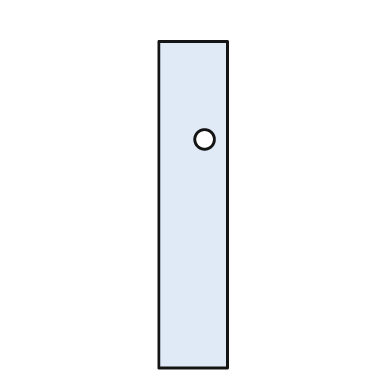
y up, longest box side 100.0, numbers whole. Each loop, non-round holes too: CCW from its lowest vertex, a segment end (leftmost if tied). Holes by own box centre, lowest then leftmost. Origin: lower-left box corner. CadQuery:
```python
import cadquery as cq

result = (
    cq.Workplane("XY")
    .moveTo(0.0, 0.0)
    .lineTo(21.0, 0.0)
    .lineTo(21.0, 100.0)
    .lineTo(0.0, 100.0)
    .close()
    .moveTo(14.0, 70.0)
    .circle(3.0)
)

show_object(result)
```